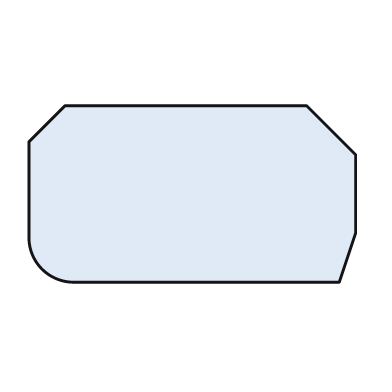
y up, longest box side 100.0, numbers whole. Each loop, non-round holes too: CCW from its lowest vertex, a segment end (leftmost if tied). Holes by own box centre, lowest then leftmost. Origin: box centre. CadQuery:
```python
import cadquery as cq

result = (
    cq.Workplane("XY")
    .moveTo(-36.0, -27.0)
    .lineTo(45.0, -27.0)
    .lineTo(50.0, -12.0)
    .lineTo(50.0, 12.0)
    .lineTo(35.0, 27.0)
    .lineTo(-39.0, 27.0)
    .lineTo(-50.0, 16.0)
    .lineTo(-50.0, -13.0)
    .threePointArc((-46.0, -23.0), (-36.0, -27.0))
    .close()
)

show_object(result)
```